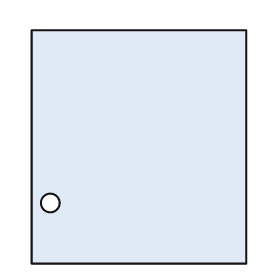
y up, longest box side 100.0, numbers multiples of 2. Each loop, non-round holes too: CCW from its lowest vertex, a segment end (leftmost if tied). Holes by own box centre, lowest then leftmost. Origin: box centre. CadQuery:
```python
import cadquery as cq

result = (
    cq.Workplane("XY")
    .moveTo(-46.0, -50.0)
    .lineTo(46.0, -50.0)
    .lineTo(46.0, 50.0)
    .lineTo(-46.0, 50.0)
    .close()
    .moveTo(-38.0, -24.0)
    .circle(4.0)
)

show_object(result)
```